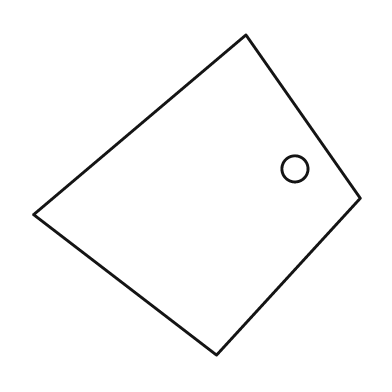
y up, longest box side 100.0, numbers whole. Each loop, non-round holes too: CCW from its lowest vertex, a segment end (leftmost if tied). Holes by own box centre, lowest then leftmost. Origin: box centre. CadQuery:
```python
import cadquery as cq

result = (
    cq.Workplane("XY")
    .moveTo(6.0, -49.0)
    .lineTo(50.0, -1.0)
    .lineTo(15.0, 49.0)
    .lineTo(-50.0, -6.0)
    .close()
    .moveTo(30.0, 8.0)
    .circle(4.0)
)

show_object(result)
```